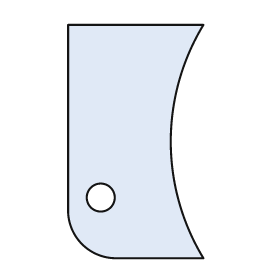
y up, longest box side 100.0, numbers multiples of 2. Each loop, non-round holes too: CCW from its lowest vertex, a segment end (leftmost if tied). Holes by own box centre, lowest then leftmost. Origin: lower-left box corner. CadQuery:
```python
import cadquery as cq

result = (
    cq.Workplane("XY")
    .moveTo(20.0, 0.0)
    .lineTo(58.0, 0.0)
    .threePointArc((44.0, 50.0), (58.0, 100.0))
    .lineTo(0.0, 100.0)
    .lineTo(0.0, 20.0)
    .threePointArc((6.0, 6.0), (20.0, 0.0))
    .close()
    .moveTo(14.0, 26.0)
    .circle(6.0)
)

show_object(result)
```